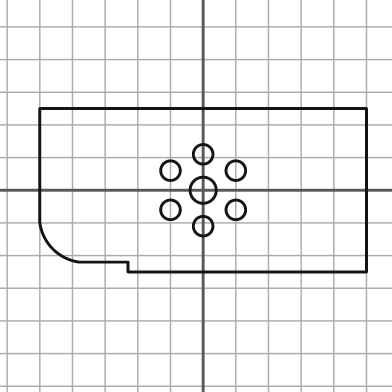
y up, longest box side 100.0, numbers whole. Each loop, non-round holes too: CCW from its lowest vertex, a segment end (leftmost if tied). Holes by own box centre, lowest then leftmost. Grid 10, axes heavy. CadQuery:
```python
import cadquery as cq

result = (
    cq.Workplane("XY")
    .moveTo(-23.0, -25.0)
    .lineTo(50.0, -25.0)
    .lineTo(50.0, 25.0)
    .lineTo(-50.0, 25.0)
    .lineTo(-50.0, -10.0)
    .threePointArc((-46.0, -18.0), (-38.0, -22.0))
    .lineTo(-23.0, -22.0)
    .close()
    .moveTo(0.0, -11.0)
    .circle(3.0)
    .moveTo(-10.0, -6.0)
    .circle(3.0)
    .moveTo(10.0, -6.0)
    .circle(3.0)
    .moveTo(0.0, 0.0)
    .circle(4.0)
    .moveTo(-10.0, 6.0)
    .circle(3.0)
    .moveTo(10.0, 6.0)
    .circle(3.0)
    .moveTo(0.0, 11.0)
    .circle(3.0)
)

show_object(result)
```